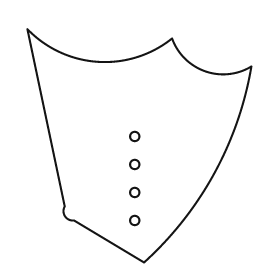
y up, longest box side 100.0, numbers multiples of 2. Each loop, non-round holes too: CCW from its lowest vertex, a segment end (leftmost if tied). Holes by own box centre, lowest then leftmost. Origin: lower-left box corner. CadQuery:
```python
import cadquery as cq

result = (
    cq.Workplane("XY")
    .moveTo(50.0, 0.0)
    .threePointArc((80.0, 38.0), (96.0, 84.0))
    .threePointArc((76.0, 82.0), (62.0, 96.0))
    .threePointArc((30.0, 86.0), (0.0, 100.0))
    .lineTo(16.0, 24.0)
    .threePointArc((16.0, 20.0), (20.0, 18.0))
    .close()
    .moveTo(46.0, 18.0)
    .circle(2.0)
    .moveTo(46.0, 30.0)
    .circle(2.0)
    .moveTo(46.0, 42.0)
    .circle(2.0)
    .moveTo(46.0, 54.0)
    .circle(2.0)
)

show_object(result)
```